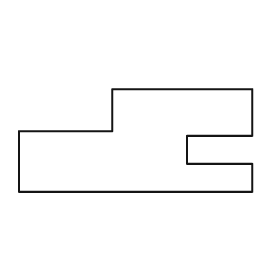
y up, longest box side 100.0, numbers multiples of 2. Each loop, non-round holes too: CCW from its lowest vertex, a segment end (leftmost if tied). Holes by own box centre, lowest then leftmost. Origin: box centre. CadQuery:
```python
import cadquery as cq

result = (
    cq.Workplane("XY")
    .moveTo(-50.0, -22.0)
    .lineTo(50.0, -22.0)
    .lineTo(50.0, -10.0)
    .lineTo(22.0, -10.0)
    .lineTo(22.0, 2.0)
    .lineTo(50.0, 2.0)
    .lineTo(50.0, 22.0)
    .lineTo(-10.0, 22.0)
    .lineTo(-10.0, 4.0)
    .lineTo(-50.0, 4.0)
    .close()
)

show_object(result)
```